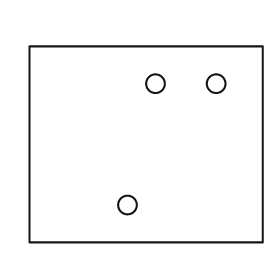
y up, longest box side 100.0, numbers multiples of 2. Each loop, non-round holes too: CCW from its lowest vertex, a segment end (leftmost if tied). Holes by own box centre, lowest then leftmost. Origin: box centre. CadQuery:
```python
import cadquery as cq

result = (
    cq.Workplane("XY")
    .moveTo(-50.0, -42.0)
    .lineTo(50.0, -42.0)
    .lineTo(50.0, 42.0)
    .lineTo(-50.0, 42.0)
    .close()
    .moveTo(-8.0, -26.0)
    .circle(4.0)
    .moveTo(4.0, 26.0)
    .circle(4.0)
    .moveTo(30.0, 26.0)
    .circle(4.0)
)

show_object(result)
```